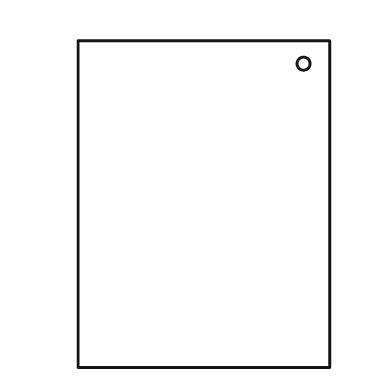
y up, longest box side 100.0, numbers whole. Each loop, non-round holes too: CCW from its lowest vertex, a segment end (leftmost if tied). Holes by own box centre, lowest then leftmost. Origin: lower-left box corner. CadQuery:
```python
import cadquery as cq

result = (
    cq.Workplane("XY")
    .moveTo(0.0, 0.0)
    .lineTo(77.0, 0.0)
    .lineTo(77.0, 100.0)
    .lineTo(0.0, 100.0)
    .close()
    .moveTo(69.0, 93.0)
    .circle(2.0)
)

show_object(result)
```